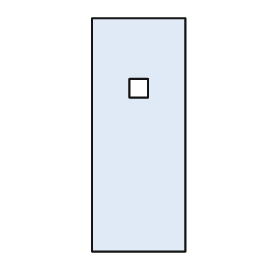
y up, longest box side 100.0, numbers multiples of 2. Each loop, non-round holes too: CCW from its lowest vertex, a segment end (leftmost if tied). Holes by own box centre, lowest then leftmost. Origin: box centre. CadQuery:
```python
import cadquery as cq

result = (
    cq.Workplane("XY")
    .moveTo(-20.0, -50.0)
    .lineTo(20.0, -50.0)
    .lineTo(20.0, 50.0)
    .lineTo(-20.0, 50.0)
    .close()
    .moveTo(-4.0, 16.0)
    .lineTo(4.0, 16.0)
    .lineTo(4.0, 24.0)
    .lineTo(-4.0, 24.0)
    .close()
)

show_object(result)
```